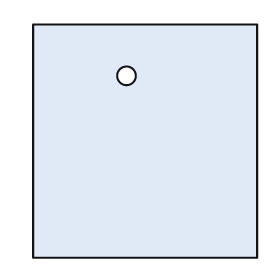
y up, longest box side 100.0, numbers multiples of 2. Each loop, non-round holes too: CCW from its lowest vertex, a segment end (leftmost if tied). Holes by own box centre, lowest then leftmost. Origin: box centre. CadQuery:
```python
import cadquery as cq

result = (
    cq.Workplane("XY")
    .moveTo(-48.0, -50.0)
    .lineTo(48.0, -50.0)
    .lineTo(48.0, 50.0)
    .lineTo(-48.0, 50.0)
    .close()
    .moveTo(-8.0, 28.0)
    .circle(4.0)
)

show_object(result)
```